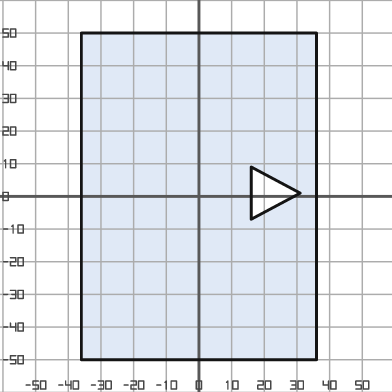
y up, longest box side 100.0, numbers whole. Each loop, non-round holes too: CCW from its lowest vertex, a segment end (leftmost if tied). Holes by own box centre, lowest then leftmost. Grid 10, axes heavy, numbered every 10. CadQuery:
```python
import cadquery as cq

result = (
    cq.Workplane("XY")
    .moveTo(-36.0, -50.0)
    .lineTo(36.0, -50.0)
    .lineTo(36.0, 50.0)
    .lineTo(-36.0, 50.0)
    .close()
    .moveTo(16.0, -7.0)
    .lineTo(31.0, 1.0)
    .lineTo(16.0, 9.0)
    .close()
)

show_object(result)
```